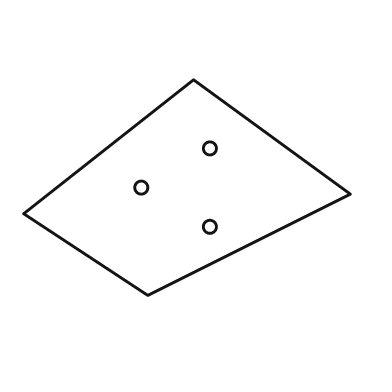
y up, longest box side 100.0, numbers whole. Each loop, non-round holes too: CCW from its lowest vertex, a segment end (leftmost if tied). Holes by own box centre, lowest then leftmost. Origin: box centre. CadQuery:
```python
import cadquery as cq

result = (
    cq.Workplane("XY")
    .moveTo(-12.0, -33.0)
    .lineTo(50.0, -2.0)
    .lineTo(2.0, 33.0)
    .lineTo(-50.0, -8.0)
    .close()
    .moveTo(7.0, -12.0)
    .circle(2.0)
    .moveTo(-14.0, 0.0)
    .circle(2.0)
    .moveTo(7.0, 12.0)
    .circle(2.0)
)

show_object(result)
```